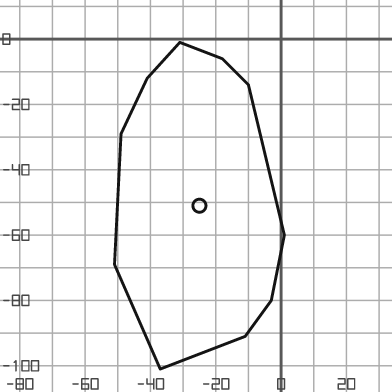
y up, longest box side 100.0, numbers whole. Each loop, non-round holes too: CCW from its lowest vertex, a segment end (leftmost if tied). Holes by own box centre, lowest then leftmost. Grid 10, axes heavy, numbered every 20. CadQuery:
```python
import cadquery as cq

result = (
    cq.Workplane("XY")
    .moveTo(-37.0, -101.0)
    .lineTo(-11.0, -91.0)
    .lineTo(-3.0, -80.0)
    .lineTo(1.0, -60.0)
    .lineTo(-10.0, -14.0)
    .lineTo(-18.0, -6.0)
    .lineTo(-31.0, -1.0)
    .lineTo(-41.0, -12.0)
    .lineTo(-49.0, -29.0)
    .lineTo(-51.0, -69.0)
    .close()
    .moveTo(-25.0, -51.0)
    .circle(2.0)
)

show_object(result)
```